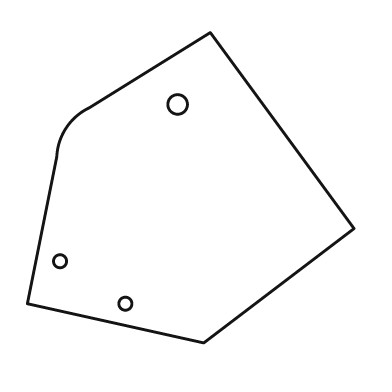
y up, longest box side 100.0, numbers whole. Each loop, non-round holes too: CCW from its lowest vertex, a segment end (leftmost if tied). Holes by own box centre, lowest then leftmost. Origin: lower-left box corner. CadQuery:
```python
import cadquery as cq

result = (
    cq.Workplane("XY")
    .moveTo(54.0, 0.0)
    .lineTo(100.0, 35.0)
    .lineTo(56.0, 95.0)
    .lineTo(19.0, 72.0)
    .threePointArc((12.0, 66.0), (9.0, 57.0))
    .lineTo(0.0, 12.0)
    .close()
    .moveTo(30.0, 12.0)
    .circle(2.0)
    .moveTo(10.0, 25.0)
    .circle(2.0)
    .moveTo(46.0, 73.0)
    .circle(3.0)
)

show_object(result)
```